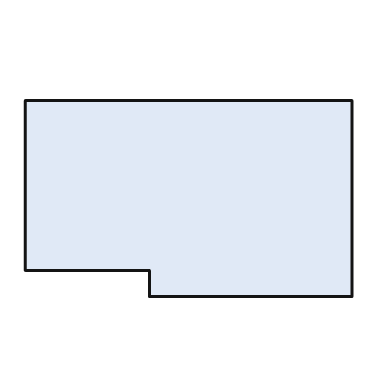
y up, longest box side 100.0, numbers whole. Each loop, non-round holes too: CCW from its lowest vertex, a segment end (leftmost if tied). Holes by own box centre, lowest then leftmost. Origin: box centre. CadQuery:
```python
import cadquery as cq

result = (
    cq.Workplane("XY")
    .moveTo(-12.0, -30.0)
    .lineTo(50.0, -30.0)
    .lineTo(50.0, 30.0)
    .lineTo(-50.0, 30.0)
    .lineTo(-50.0, -22.0)
    .lineTo(-12.0, -22.0)
    .close()
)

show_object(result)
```